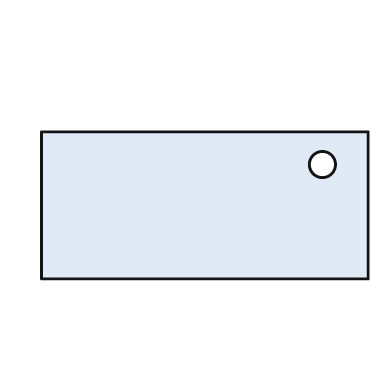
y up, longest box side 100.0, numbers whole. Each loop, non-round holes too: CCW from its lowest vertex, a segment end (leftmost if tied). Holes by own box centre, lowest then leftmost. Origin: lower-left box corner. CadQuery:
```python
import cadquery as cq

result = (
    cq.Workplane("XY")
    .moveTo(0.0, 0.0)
    .lineTo(100.0, 0.0)
    .lineTo(100.0, 45.0)
    .lineTo(0.0, 45.0)
    .close()
    .moveTo(86.0, 35.0)
    .circle(4.0)
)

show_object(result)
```